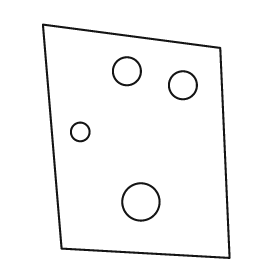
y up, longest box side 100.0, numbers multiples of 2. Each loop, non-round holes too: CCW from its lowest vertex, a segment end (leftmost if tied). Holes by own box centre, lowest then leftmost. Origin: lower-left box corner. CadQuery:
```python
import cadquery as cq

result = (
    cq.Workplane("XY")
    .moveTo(80.0, 0.0)
    .lineTo(76.0, 90.0)
    .lineTo(0.0, 100.0)
    .lineTo(8.0, 4.0)
    .close()
    .moveTo(42.0, 24.0)
    .circle(8.0)
    .moveTo(16.0, 54.0)
    .circle(4.0)
    .moveTo(60.0, 74.0)
    .circle(6.0)
    .moveTo(36.0, 80.0)
    .circle(6.0)
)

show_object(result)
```